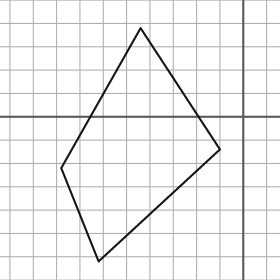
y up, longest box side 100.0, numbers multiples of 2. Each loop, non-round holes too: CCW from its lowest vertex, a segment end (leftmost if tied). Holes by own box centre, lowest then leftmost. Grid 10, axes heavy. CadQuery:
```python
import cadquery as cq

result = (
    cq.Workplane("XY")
    .moveTo(-62.0, -62.0)
    .lineTo(-10.0, -14.0)
    .lineTo(-44.0, 38.0)
    .lineTo(-78.0, -22.0)
    .close()
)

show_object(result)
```